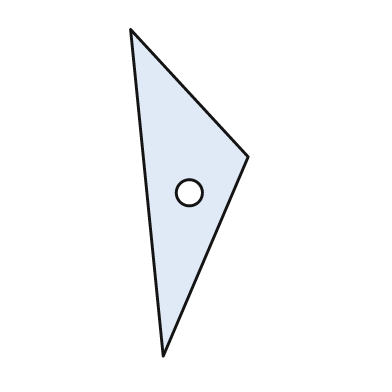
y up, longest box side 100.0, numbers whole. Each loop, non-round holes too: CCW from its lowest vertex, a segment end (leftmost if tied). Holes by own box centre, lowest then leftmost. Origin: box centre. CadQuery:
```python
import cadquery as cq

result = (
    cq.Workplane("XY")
    .moveTo(-8.0, -50.0)
    .lineTo(18.0, 11.0)
    .lineTo(-18.0, 50.0)
    .close()
    .moveTo(0.0, 0.0)
    .circle(4.0)
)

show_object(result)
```